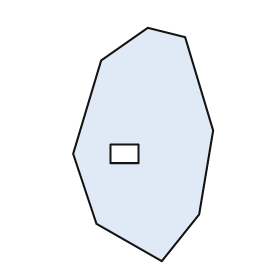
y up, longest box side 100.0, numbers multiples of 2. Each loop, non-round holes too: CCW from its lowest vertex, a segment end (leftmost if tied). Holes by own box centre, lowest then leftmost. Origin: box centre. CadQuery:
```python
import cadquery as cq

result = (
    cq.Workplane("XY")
    .moveTo(8.0, -50.0)
    .lineTo(24.0, -30.0)
    .lineTo(30.0, 6.0)
    .lineTo(18.0, 46.0)
    .lineTo(2.0, 50.0)
    .lineTo(-18.0, 36.0)
    .lineTo(-30.0, -4.0)
    .lineTo(-20.0, -34.0)
    .close()
    .moveTo(-14.0, -8.0)
    .lineTo(-2.0, -8.0)
    .lineTo(-2.0, 0.0)
    .lineTo(-14.0, 0.0)
    .close()
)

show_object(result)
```